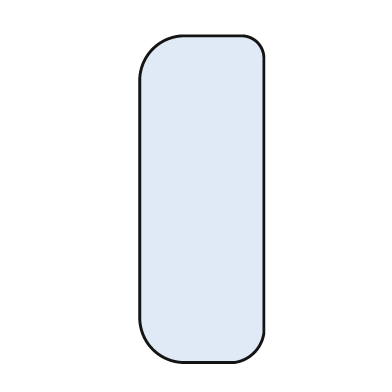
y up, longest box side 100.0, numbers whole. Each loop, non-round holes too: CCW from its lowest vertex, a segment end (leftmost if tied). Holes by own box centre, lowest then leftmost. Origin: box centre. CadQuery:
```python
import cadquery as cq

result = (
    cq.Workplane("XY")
    .moveTo(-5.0, -50.0)
    .lineTo(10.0, -50.0)
    .threePointArc((16.0, -47.0), (19.0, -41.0))
    .lineTo(19.0, 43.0)
    .threePointArc((17.0, 48.0), (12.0, 50.0))
    .lineTo(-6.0, 50.0)
    .threePointArc((-15.0, 46.0), (-19.0, 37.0))
    .lineTo(-19.0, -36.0)
    .threePointArc((-15.0, -46.0), (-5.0, -50.0))
    .close()
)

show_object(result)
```